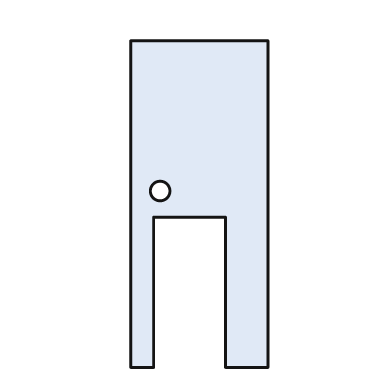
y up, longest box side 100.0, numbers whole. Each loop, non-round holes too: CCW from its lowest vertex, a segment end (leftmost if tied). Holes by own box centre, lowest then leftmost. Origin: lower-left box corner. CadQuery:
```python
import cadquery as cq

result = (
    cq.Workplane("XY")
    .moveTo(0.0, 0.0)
    .lineTo(7.0, 0.0)
    .lineTo(7.0, 46.0)
    .lineTo(29.0, 46.0)
    .lineTo(29.0, 0.0)
    .lineTo(42.0, 0.0)
    .lineTo(42.0, 100.0)
    .lineTo(0.0, 100.0)
    .close()
    .moveTo(9.0, 54.0)
    .circle(3.0)
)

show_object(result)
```